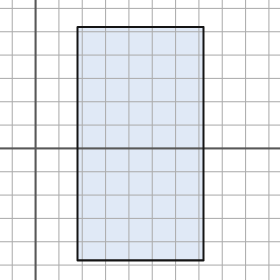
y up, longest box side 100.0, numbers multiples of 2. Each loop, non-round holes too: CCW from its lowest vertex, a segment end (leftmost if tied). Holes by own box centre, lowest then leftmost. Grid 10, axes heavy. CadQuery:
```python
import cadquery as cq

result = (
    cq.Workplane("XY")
    .moveTo(18.0, -48.0)
    .lineTo(72.0, -48.0)
    .lineTo(72.0, 52.0)
    .lineTo(18.0, 52.0)
    .close()
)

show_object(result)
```